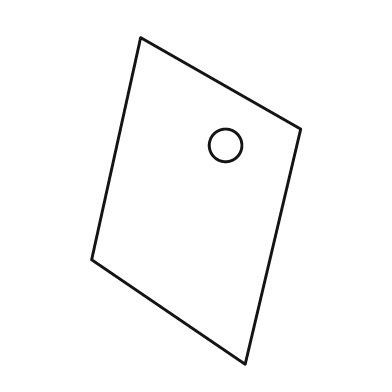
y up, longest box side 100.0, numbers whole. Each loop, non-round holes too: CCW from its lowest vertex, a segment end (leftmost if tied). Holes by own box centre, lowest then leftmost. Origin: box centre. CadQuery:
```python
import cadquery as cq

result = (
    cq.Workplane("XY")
    .moveTo(15.0, -50.0)
    .lineTo(32.0, 22.0)
    .lineTo(-17.0, 50.0)
    .lineTo(-32.0, -18.0)
    .close()
    .moveTo(9.0, 17.0)
    .circle(5.0)
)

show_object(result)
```